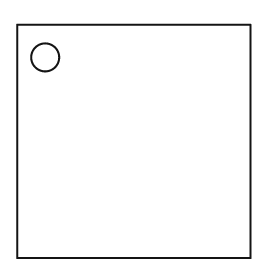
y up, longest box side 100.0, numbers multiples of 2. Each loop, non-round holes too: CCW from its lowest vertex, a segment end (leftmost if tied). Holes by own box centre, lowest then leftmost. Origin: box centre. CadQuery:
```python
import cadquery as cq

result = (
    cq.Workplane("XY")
    .moveTo(-50.0, -50.0)
    .lineTo(50.0, -50.0)
    .lineTo(50.0, 50.0)
    .lineTo(-50.0, 50.0)
    .close()
    .moveTo(-38.0, 36.0)
    .circle(6.0)
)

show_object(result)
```